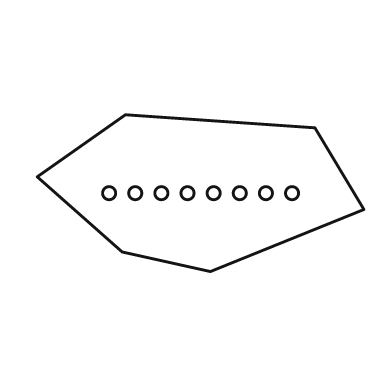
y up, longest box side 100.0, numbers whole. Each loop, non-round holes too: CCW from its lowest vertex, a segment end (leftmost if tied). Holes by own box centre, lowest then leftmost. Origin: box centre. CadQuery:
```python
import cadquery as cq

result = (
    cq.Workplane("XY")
    .moveTo(3.0, -24.0)
    .lineTo(50.0, -5.0)
    .lineTo(35.0, 20.0)
    .lineTo(-23.0, 24.0)
    .lineTo(-50.0, 5.0)
    .lineTo(-24.0, -18.0)
    .close()
    .moveTo(-28.0, 0.0)
    .circle(2.0)
    .moveTo(-20.0, 0.0)
    .circle(2.0)
    .moveTo(-12.0, 0.0)
    .circle(2.0)
    .moveTo(-4.0, 0.0)
    .circle(2.0)
    .moveTo(4.0, 0.0)
    .circle(2.0)
    .moveTo(12.0, 0.0)
    .circle(2.0)
    .moveTo(20.0, 0.0)
    .circle(2.0)
    .moveTo(28.0, 0.0)
    .circle(2.0)
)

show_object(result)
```